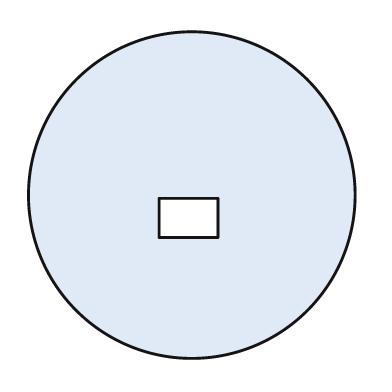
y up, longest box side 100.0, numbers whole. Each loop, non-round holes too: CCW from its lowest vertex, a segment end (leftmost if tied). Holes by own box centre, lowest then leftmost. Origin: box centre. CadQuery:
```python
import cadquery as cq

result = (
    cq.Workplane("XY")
    .moveTo(0.0, 0.0)
    .circle(50.0)
    .moveTo(-10.0, -13.0)
    .lineTo(8.0, -13.0)
    .lineTo(8.0, -1.0)
    .lineTo(-10.0, -1.0)
    .close()
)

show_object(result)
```